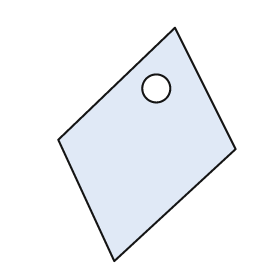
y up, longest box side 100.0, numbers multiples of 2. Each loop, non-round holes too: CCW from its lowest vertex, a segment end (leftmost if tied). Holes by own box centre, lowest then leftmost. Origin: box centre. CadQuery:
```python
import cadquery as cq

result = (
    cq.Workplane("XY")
    .moveTo(-14.0, -50.0)
    .lineTo(38.0, -2.0)
    .lineTo(12.0, 50.0)
    .lineTo(-38.0, 2.0)
    .close()
    .moveTo(4.0, 24.0)
    .circle(6.0)
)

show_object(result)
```